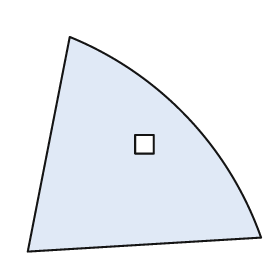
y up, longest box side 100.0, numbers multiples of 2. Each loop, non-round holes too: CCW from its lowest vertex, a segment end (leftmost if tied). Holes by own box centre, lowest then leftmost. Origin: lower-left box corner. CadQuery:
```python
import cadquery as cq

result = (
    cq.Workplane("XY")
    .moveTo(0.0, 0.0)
    .lineTo(100.0, 6.0)
    .threePointArc((68.0, 58.0), (18.0, 92.0))
    .close()
    .moveTo(46.0, 42.0)
    .lineTo(54.0, 42.0)
    .lineTo(54.0, 50.0)
    .lineTo(46.0, 50.0)
    .close()
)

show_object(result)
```